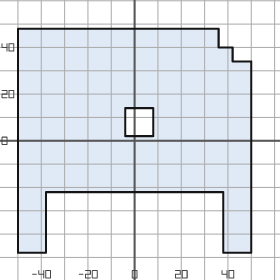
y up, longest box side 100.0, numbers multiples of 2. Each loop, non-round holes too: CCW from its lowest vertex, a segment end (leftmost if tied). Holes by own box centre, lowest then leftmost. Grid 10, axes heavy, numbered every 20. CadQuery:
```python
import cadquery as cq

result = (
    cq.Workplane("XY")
    .moveTo(-50.0, -48.0)
    .lineTo(-38.0, -48.0)
    .lineTo(-38.0, -22.0)
    .lineTo(38.0, -22.0)
    .lineTo(38.0, -48.0)
    .lineTo(50.0, -48.0)
    .lineTo(50.0, 34.0)
    .lineTo(42.0, 34.0)
    .lineTo(42.0, 40.0)
    .lineTo(36.0, 40.0)
    .lineTo(36.0, 48.0)
    .lineTo(-50.0, 48.0)
    .close()
    .moveTo(-4.0, 2.0)
    .lineTo(8.0, 2.0)
    .lineTo(8.0, 14.0)
    .lineTo(-4.0, 14.0)
    .close()
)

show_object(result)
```